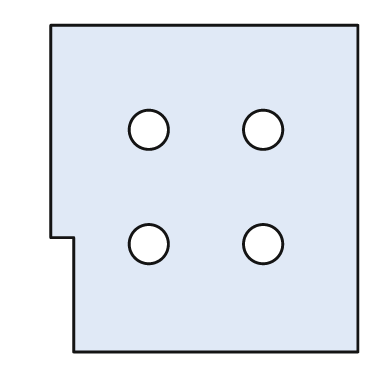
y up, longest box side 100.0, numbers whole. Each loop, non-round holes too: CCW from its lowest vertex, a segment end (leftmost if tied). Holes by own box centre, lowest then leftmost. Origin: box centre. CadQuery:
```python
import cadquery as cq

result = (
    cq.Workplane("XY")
    .moveTo(-40.0, -50.0)
    .lineTo(47.0, -50.0)
    .lineTo(47.0, 50.0)
    .lineTo(-47.0, 50.0)
    .lineTo(-47.0, -15.0)
    .lineTo(-40.0, -15.0)
    .close()
    .moveTo(-17.0, -17.0)
    .circle(6.0)
    .moveTo(18.0, -17.0)
    .circle(6.0)
    .moveTo(-17.0, 18.0)
    .circle(6.0)
    .moveTo(18.0, 18.0)
    .circle(6.0)
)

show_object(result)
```